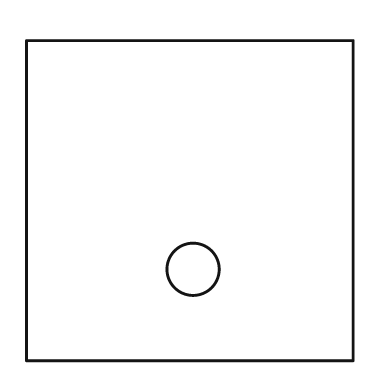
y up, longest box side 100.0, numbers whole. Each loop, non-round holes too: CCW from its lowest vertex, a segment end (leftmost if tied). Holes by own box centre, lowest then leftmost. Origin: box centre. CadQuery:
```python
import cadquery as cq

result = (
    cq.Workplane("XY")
    .moveTo(-50.0, -49.0)
    .lineTo(50.0, -49.0)
    .lineTo(50.0, 49.0)
    .lineTo(-50.0, 49.0)
    .close()
    .moveTo(1.0, -21.0)
    .circle(8.0)
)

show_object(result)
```